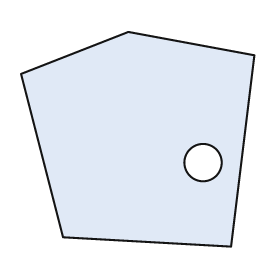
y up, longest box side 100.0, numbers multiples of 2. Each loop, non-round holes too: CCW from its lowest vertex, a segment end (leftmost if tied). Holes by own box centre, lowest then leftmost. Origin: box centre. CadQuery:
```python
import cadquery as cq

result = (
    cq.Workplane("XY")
    .moveTo(40.0, -46.0)
    .lineTo(50.0, 36.0)
    .lineTo(-4.0, 46.0)
    .lineTo(-50.0, 28.0)
    .lineTo(-32.0, -42.0)
    .close()
    .moveTo(28.0, -10.0)
    .circle(8.0)
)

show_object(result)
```